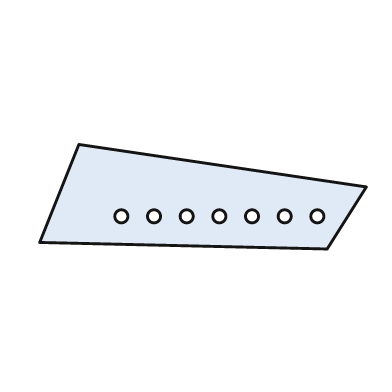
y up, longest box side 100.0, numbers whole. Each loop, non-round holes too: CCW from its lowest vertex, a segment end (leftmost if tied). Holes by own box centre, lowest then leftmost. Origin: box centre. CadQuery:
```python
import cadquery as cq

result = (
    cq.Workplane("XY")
    .moveTo(38.0, -16.0)
    .lineTo(50.0, 3.0)
    .lineTo(-38.0, 16.0)
    .lineTo(-50.0, -14.0)
    .close()
    .moveTo(-25.0, -6.0)
    .circle(2.0)
    .moveTo(-15.0, -6.0)
    .circle(2.0)
    .moveTo(-5.0, -6.0)
    .circle(2.0)
    .moveTo(5.0, -6.0)
    .circle(2.0)
    .moveTo(15.0, -6.0)
    .circle(2.0)
    .moveTo(25.0, -6.0)
    .circle(2.0)
    .moveTo(35.0, -6.0)
    .circle(2.0)
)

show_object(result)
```